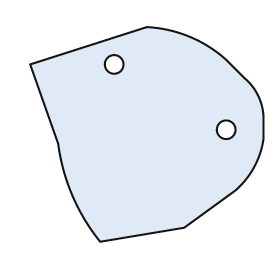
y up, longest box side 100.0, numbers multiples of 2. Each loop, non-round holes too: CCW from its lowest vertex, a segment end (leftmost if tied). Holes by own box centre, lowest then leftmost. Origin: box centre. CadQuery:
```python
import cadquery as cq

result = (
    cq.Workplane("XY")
    .moveTo(-20.0, -46.0)
    .lineTo(16.0, -40.0)
    .lineTo(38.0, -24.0)
    .threePointArc((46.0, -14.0), (50.0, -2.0))
    .lineTo(50.0, 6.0)
    .threePointArc((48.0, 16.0), (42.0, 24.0))
    .lineTo(34.0, 32.0)
    .threePointArc((18.0, 42.0), (0.0, 46.0))
    .lineTo(-50.0, 30.0)
    .lineTo(-38.0, -4.0)
    .threePointArc((-32.0, -26.0), (-20.0, -46.0))
    .close()
    .moveTo(34.0, 2.0)
    .circle(4.0)
    .moveTo(-14.0, 30.0)
    .circle(4.0)
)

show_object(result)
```